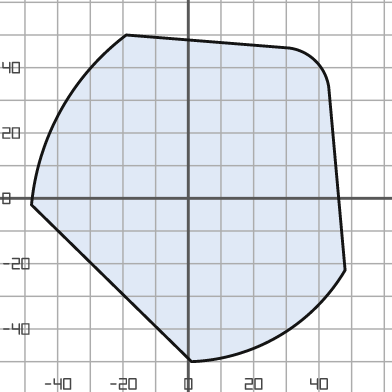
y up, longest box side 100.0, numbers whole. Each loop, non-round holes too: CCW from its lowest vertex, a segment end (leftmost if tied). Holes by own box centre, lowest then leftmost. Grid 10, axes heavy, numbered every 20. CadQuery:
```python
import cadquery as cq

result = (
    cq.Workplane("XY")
    .moveTo(1.0, -50.0)
    .threePointArc((28.0, -42.0), (48.0, -22.0))
    .lineTo(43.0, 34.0)
    .threePointArc((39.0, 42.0), (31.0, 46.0))
    .lineTo(-19.0, 50.0)
    .threePointArc((-39.0, 27.0), (-48.0, -2.0))
    .close()
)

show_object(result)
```